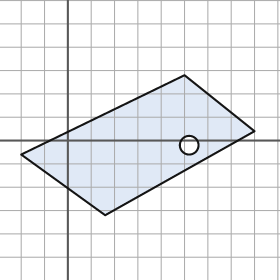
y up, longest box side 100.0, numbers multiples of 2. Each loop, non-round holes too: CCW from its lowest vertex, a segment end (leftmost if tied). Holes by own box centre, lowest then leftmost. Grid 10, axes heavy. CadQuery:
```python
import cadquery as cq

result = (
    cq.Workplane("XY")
    .moveTo(16.0, -32.0)
    .lineTo(80.0, 4.0)
    .lineTo(50.0, 28.0)
    .lineTo(-20.0, -6.0)
    .close()
    .moveTo(52.0, -2.0)
    .circle(4.0)
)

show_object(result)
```